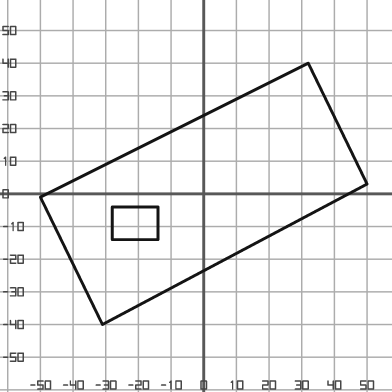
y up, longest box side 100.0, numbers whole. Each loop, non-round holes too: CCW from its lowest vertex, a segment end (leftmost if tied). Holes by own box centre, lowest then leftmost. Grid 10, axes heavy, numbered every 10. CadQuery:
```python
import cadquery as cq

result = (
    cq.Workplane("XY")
    .moveTo(-31.0, -40.0)
    .lineTo(50.0, 3.0)
    .lineTo(32.0, 40.0)
    .lineTo(-50.0, -1.0)
    .close()
    .moveTo(-28.0, -14.0)
    .lineTo(-14.0, -14.0)
    .lineTo(-14.0, -4.0)
    .lineTo(-28.0, -4.0)
    .close()
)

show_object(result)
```